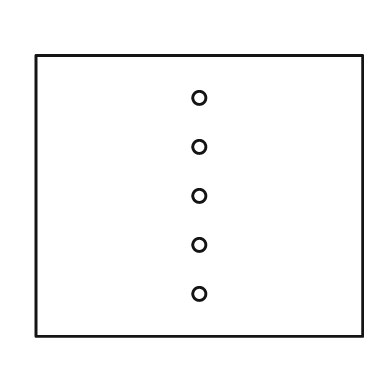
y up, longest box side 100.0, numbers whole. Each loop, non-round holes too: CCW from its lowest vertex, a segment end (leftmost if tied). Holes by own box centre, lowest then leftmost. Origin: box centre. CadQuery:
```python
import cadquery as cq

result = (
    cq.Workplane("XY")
    .moveTo(-50.0, -43.0)
    .lineTo(50.0, -43.0)
    .lineTo(50.0, 43.0)
    .lineTo(-50.0, 43.0)
    .close()
    .moveTo(0.0, -30.0)
    .circle(2.0)
    .moveTo(0.0, -15.0)
    .circle(2.0)
    .moveTo(0.0, 0.0)
    .circle(2.0)
    .moveTo(0.0, 15.0)
    .circle(2.0)
    .moveTo(0.0, 30.0)
    .circle(2.0)
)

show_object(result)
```